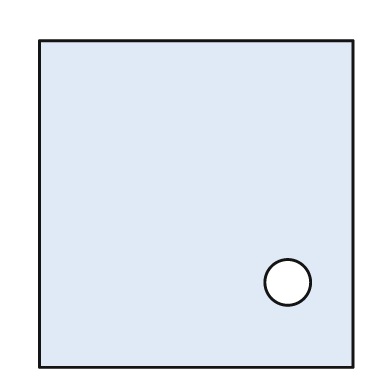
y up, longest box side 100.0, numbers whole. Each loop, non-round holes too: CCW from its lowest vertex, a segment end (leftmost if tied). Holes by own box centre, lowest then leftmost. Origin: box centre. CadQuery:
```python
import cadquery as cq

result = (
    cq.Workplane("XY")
    .moveTo(-48.0, -50.0)
    .lineTo(48.0, -50.0)
    .lineTo(48.0, 50.0)
    .lineTo(-48.0, 50.0)
    .close()
    .moveTo(28.0, -24.0)
    .circle(7.0)
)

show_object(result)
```